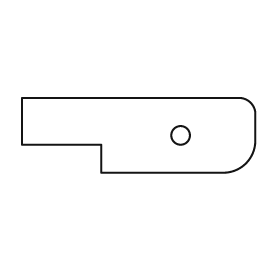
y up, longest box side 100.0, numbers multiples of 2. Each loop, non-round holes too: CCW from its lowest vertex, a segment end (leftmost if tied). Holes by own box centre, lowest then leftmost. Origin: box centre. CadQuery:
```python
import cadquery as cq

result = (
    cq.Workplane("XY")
    .moveTo(-16.0, -16.0)
    .lineTo(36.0, -16.0)
    .threePointArc((46.0, -12.0), (50.0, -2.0))
    .lineTo(50.0, 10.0)
    .threePointArc((48.0, 14.0), (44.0, 16.0))
    .lineTo(-50.0, 16.0)
    .lineTo(-50.0, -4.0)
    .lineTo(-16.0, -4.0)
    .close()
    .moveTo(18.0, 0.0)
    .circle(4.0)
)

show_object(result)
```